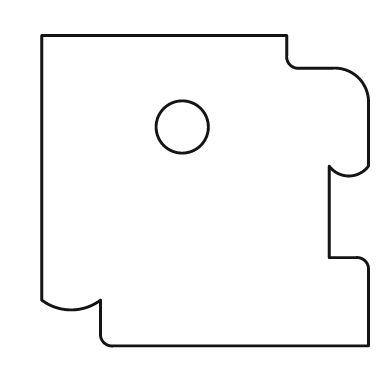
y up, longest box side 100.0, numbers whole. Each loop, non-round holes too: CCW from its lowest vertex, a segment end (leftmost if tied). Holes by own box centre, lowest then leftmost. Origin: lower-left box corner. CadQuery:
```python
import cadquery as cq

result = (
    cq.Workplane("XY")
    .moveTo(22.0, 0.0)
    .lineTo(100.0, 0.0)
    .lineTo(100.0, 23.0)
    .threePointArc((99.0, 26.0), (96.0, 27.0))
    .lineTo(88.0, 27.0)
    .lineTo(88.0, 55.0)
    .threePointArc((94.0, 52.0), (100.0, 55.0))
    .lineTo(100.0, 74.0)
    .threePointArc((97.0, 82.0), (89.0, 85.0))
    .lineTo(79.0, 85.0)
    .threePointArc((76.0, 86.0), (75.0, 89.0))
    .lineTo(75.0, 95.0)
    .lineTo(0.0, 95.0)
    .lineTo(0.0, 14.0)
    .threePointArc((9.0, 11.0), (18.0, 14.0))
    .lineTo(18.0, 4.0)
    .threePointArc((19.0, 1.0), (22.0, 0.0))
    .close()
    .moveTo(43.0, 67.0)
    .circle(8.0)
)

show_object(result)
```